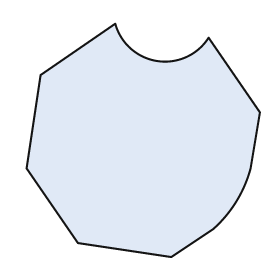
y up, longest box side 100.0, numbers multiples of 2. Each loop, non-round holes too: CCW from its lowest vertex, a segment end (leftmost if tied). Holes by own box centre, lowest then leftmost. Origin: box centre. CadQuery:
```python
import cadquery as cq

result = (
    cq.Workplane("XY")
    .moveTo(12.0, -50.0)
    .lineTo(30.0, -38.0)
    .threePointArc((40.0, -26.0), (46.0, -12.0))
    .lineTo(50.0, 12.0)
    .lineTo(28.0, 44.0)
    .threePointArc((6.0, 34.0), (-12.0, 50.0))
    .lineTo(-44.0, 28.0)
    .lineTo(-50.0, -12.0)
    .lineTo(-28.0, -44.0)
    .close()
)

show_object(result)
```